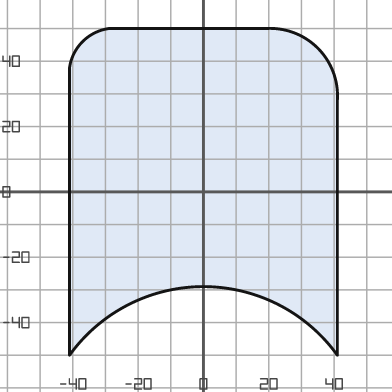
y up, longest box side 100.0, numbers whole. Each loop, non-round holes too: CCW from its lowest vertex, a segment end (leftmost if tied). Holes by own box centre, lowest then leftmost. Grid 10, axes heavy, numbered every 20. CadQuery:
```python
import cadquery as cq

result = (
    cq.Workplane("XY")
    .moveTo(-41.0, -50.0)
    .threePointArc((0.0, -29.0), (41.0, -50.0))
    .lineTo(41.0, 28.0)
    .threePointArc((35.0, 44.0), (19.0, 50.0))
    .lineTo(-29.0, 50.0)
    .threePointArc((-37.0, 46.0), (-41.0, 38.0))
    .close()
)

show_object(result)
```